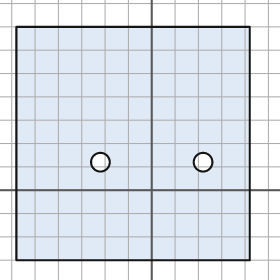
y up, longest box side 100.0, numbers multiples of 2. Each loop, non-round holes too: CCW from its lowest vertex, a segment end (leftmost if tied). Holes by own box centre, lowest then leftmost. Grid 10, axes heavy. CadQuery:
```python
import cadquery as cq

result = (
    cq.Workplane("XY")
    .moveTo(-58.0, -30.0)
    .lineTo(42.0, -30.0)
    .lineTo(42.0, 70.0)
    .lineTo(-58.0, 70.0)
    .close()
    .moveTo(-22.0, 12.0)
    .circle(4.0)
    .moveTo(22.0, 12.0)
    .circle(4.0)
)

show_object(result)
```